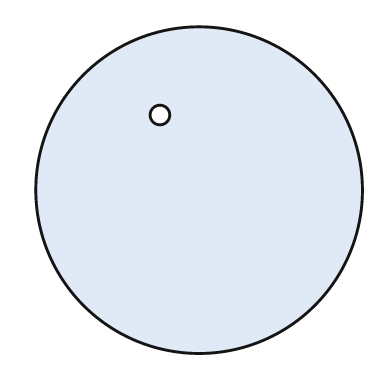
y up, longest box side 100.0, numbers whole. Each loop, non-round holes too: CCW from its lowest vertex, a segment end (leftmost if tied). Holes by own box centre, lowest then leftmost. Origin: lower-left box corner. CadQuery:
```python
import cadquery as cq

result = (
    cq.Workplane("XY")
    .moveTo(50.0, 50.0)
    .circle(50.0)
    .moveTo(38.0, 73.0)
    .circle(3.0)
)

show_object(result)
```